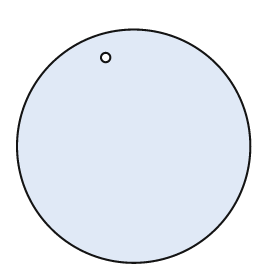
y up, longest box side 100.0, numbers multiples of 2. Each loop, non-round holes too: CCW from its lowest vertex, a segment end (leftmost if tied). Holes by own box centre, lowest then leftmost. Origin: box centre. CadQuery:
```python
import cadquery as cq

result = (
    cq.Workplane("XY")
    .moveTo(0.0, 0.0)
    .circle(50.0)
    .moveTo(-12.0, 38.0)
    .circle(2.0)
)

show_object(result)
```